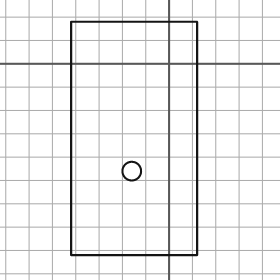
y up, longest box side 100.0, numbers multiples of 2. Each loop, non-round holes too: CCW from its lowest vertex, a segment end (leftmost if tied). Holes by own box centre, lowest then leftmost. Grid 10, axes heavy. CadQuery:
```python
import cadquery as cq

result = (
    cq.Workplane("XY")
    .moveTo(-42.0, -82.0)
    .lineTo(12.0, -82.0)
    .lineTo(12.0, 18.0)
    .lineTo(-42.0, 18.0)
    .close()
    .moveTo(-16.0, -46.0)
    .circle(4.0)
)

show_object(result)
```